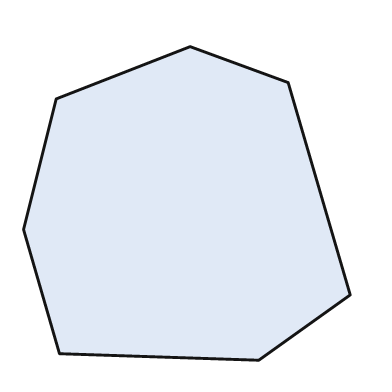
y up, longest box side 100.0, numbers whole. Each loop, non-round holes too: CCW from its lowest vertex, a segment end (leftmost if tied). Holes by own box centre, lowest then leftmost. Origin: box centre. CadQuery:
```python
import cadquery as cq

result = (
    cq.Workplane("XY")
    .moveTo(22.0, -48.0)
    .lineTo(50.0, -28.0)
    .lineTo(31.0, 37.0)
    .lineTo(1.0, 48.0)
    .lineTo(-40.0, 32.0)
    .lineTo(-50.0, -8.0)
    .lineTo(-39.0, -46.0)
    .close()
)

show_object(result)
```